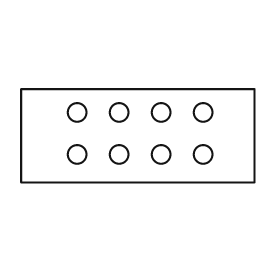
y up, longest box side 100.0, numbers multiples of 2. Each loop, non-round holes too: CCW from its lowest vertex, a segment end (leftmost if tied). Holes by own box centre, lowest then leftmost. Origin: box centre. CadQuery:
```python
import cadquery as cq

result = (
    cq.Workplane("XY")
    .moveTo(-50.0, -20.0)
    .lineTo(50.0, -20.0)
    .lineTo(50.0, 20.0)
    .lineTo(-50.0, 20.0)
    .close()
    .moveTo(-26.0, -8.0)
    .circle(4.0)
    .moveTo(-8.0, -8.0)
    .circle(4.0)
    .moveTo(10.0, -8.0)
    .circle(4.0)
    .moveTo(28.0, -8.0)
    .circle(4.0)
    .moveTo(-26.0, 10.0)
    .circle(4.0)
    .moveTo(-8.0, 10.0)
    .circle(4.0)
    .moveTo(10.0, 10.0)
    .circle(4.0)
    .moveTo(28.0, 10.0)
    .circle(4.0)
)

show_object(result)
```